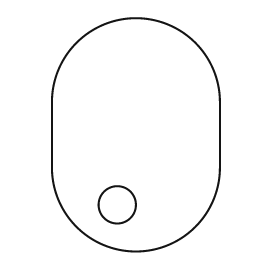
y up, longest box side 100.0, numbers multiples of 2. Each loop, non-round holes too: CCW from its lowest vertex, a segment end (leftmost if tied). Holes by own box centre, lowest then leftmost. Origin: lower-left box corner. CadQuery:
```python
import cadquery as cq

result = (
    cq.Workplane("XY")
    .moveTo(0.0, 36.0)
    .threePointArc((36.0, 0.0), (72.0, 36.0))
    .lineTo(72.0, 64.0)
    .threePointArc((36.0, 100.0), (0.0, 64.0))
    .close()
    .moveTo(28.0, 20.0)
    .circle(8.0)
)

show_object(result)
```